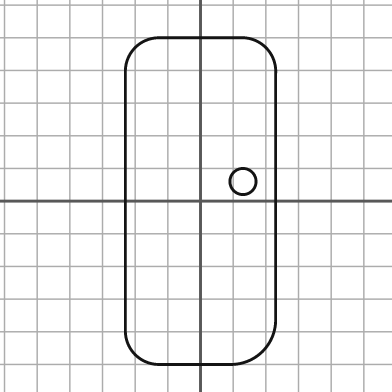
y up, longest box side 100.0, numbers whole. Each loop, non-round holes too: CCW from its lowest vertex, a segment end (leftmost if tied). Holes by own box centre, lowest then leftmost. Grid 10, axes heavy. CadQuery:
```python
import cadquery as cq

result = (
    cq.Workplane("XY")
    .moveTo(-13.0, -50.0)
    .lineTo(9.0, -50.0)
    .threePointArc((19.0, -46.0), (23.0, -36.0))
    .lineTo(23.0, 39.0)
    .threePointArc((20.0, 47.0), (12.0, 50.0))
    .lineTo(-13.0, 50.0)
    .threePointArc((-20.0, 47.0), (-23.0, 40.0))
    .lineTo(-23.0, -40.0)
    .threePointArc((-20.0, -47.0), (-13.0, -50.0))
    .close()
    .moveTo(13.0, 6.0)
    .circle(4.0)
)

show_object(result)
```